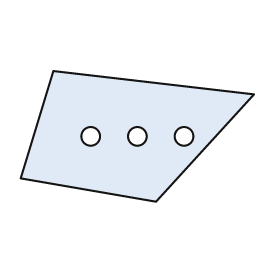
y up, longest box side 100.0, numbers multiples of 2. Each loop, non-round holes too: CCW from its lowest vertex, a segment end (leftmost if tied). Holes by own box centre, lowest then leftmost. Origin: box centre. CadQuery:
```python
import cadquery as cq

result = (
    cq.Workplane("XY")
    .moveTo(8.0, -28.0)
    .lineTo(50.0, 18.0)
    .lineTo(-36.0, 28.0)
    .lineTo(-50.0, -18.0)
    .close()
    .moveTo(-20.0, 0.0)
    .circle(4.0)
    .moveTo(0.0, 0.0)
    .circle(4.0)
    .moveTo(20.0, 0.0)
    .circle(4.0)
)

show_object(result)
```